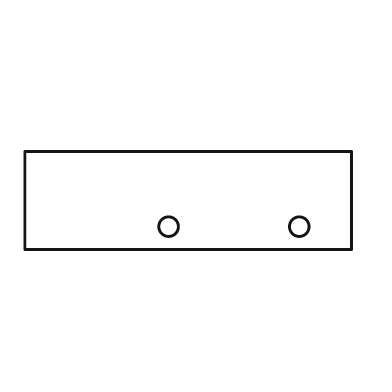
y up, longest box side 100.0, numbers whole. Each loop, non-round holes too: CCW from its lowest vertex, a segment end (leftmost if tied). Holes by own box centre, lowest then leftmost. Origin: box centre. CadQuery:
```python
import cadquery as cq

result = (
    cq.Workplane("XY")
    .moveTo(-50.0, -15.0)
    .lineTo(50.0, -15.0)
    .lineTo(50.0, 15.0)
    .lineTo(-50.0, 15.0)
    .close()
    .moveTo(-6.0, -8.0)
    .circle(3.0)
    .moveTo(34.0, -8.0)
    .circle(3.0)
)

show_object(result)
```